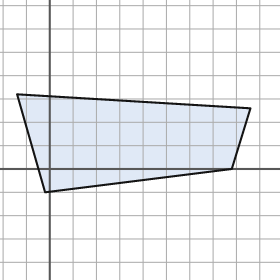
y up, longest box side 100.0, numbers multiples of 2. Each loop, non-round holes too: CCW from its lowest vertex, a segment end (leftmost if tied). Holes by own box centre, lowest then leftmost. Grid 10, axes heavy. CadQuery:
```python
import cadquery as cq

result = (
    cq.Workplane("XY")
    .moveTo(-2.0, -10.0)
    .lineTo(78.0, 0.0)
    .lineTo(86.0, 26.0)
    .lineTo(-14.0, 32.0)
    .close()
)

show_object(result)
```